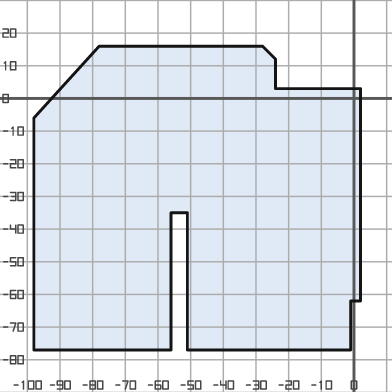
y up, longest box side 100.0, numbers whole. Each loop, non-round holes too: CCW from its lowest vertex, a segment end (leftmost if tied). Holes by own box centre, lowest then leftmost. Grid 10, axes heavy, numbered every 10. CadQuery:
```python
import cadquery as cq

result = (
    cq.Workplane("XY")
    .moveTo(-98.0, -77.0)
    .lineTo(-56.0, -77.0)
    .lineTo(-56.0, -35.0)
    .lineTo(-51.0, -35.0)
    .lineTo(-51.0, -77.0)
    .lineTo(-1.0, -77.0)
    .lineTo(-1.0, -62.0)
    .lineTo(2.0, -62.0)
    .lineTo(2.0, 3.0)
    .lineTo(-24.0, 3.0)
    .lineTo(-24.0, 12.0)
    .lineTo(-28.0, 16.0)
    .lineTo(-78.0, 16.0)
    .lineTo(-98.0, -6.0)
    .close()
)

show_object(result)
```